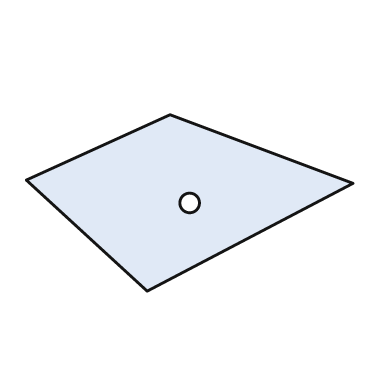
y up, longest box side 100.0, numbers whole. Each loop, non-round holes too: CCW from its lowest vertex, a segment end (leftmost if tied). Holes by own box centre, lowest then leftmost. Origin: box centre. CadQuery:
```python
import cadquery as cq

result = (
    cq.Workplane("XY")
    .moveTo(-13.0, -27.0)
    .lineTo(50.0, 6.0)
    .lineTo(-6.0, 27.0)
    .lineTo(-50.0, 7.0)
    .close()
    .moveTo(0.0, 0.0)
    .circle(3.0)
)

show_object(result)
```